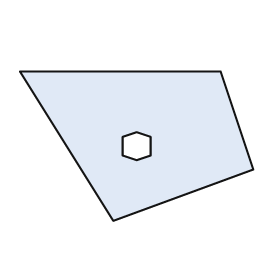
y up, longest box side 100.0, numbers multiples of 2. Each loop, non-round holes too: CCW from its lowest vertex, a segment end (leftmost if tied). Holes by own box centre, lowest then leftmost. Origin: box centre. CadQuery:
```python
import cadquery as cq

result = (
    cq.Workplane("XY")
    .moveTo(-10.0, -32.0)
    .lineTo(50.0, -10.0)
    .lineTo(36.0, 32.0)
    .lineTo(-50.0, 32.0)
    .close()
    .moveTo(0.0, -6.0)
    .lineTo(6.0, -4.0)
    .lineTo(6.0, 4.0)
    .lineTo(0.0, 6.0)
    .lineTo(-6.0, 4.0)
    .lineTo(-6.0, -4.0)
    .close()
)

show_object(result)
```